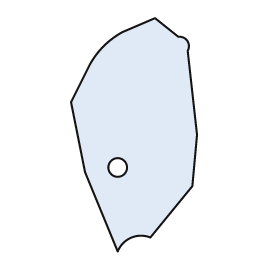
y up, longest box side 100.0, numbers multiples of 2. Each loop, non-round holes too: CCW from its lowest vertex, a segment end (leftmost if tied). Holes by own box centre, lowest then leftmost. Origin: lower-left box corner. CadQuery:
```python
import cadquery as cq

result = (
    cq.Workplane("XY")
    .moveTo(20.0, 0.0)
    .threePointArc((26.0, 6.0), (34.0, 6.0))
    .lineTo(52.0, 28.0)
    .lineTo(54.0, 50.0)
    .lineTo(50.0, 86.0)
    .threePointArc((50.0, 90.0), (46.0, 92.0))
    .lineTo(36.0, 100.0)
    .lineTo(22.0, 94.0)
    .threePointArc((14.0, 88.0), (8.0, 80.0))
    .lineTo(0.0, 64.0)
    .lineTo(6.0, 34.0)
    .close()
    .moveTo(20.0, 36.0)
    .circle(4.0)
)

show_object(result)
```